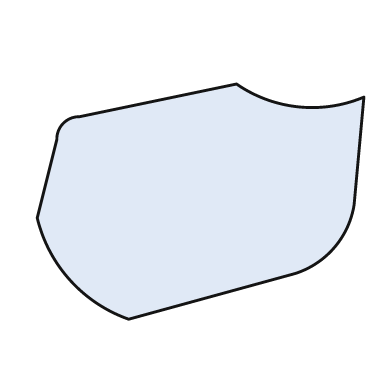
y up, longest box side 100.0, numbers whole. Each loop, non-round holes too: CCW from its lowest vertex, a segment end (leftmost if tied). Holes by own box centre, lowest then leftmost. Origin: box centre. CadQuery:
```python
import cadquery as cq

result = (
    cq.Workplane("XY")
    .moveTo(-22.0, -36.0)
    .lineTo(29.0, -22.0)
    .threePointArc((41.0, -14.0), (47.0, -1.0))
    .lineTo(50.0, 32.0)
    .threePointArc((30.0, 29.0), (11.0, 36.0))
    .lineTo(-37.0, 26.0)
    .threePointArc((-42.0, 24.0), (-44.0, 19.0))
    .lineTo(-50.0, -5.0)
    .threePointArc((-40.0, -24.0), (-22.0, -36.0))
    .close()
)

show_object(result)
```